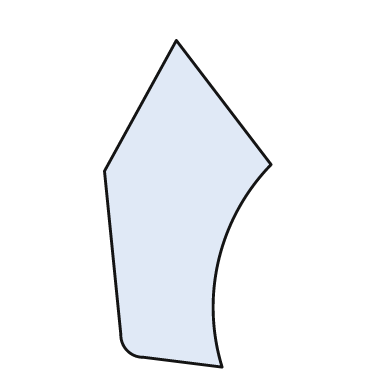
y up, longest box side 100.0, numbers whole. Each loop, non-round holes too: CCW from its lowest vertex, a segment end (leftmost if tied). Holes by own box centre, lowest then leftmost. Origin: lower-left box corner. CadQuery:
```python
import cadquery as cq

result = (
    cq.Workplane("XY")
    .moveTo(36.0, 0.0)
    .threePointArc((35.0, 33.0), (51.0, 62.0))
    .lineTo(22.0, 100.0)
    .lineTo(0.0, 60.0)
    .lineTo(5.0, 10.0)
    .threePointArc((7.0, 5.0), (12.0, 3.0))
    .close()
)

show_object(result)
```